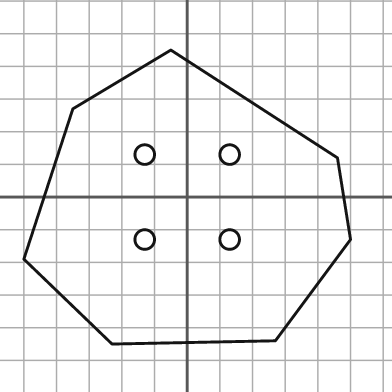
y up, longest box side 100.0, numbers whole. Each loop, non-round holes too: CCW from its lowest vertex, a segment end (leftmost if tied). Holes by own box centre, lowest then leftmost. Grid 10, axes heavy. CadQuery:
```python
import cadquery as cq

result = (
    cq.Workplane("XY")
    .moveTo(-23.0, -45.0)
    .lineTo(27.0, -44.0)
    .lineTo(50.0, -13.0)
    .lineTo(46.0, 12.0)
    .lineTo(-5.0, 45.0)
    .lineTo(-35.0, 27.0)
    .lineTo(-50.0, -19.0)
    .close()
    .moveTo(-13.0, -13.0)
    .circle(3.0)
    .moveTo(13.0, -13.0)
    .circle(3.0)
    .moveTo(-13.0, 13.0)
    .circle(3.0)
    .moveTo(13.0, 13.0)
    .circle(3.0)
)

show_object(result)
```